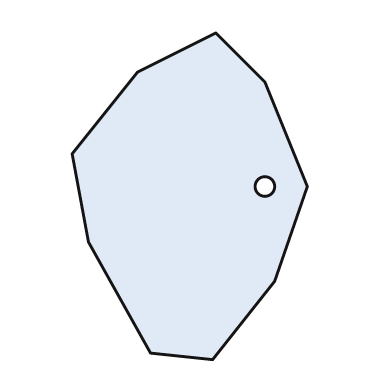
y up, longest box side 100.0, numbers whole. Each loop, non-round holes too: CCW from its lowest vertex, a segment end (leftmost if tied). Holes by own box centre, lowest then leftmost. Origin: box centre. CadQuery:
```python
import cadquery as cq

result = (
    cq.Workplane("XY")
    .moveTo(7.0, -50.0)
    .lineTo(26.0, -26.0)
    .lineTo(36.0, 3.0)
    .lineTo(23.0, 35.0)
    .lineTo(8.0, 50.0)
    .lineTo(-16.0, 38.0)
    .lineTo(-36.0, 13.0)
    .lineTo(-31.0, -14.0)
    .lineTo(-12.0, -48.0)
    .close()
    .moveTo(23.0, 3.0)
    .circle(3.0)
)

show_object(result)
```